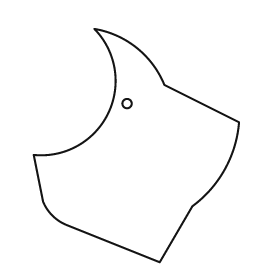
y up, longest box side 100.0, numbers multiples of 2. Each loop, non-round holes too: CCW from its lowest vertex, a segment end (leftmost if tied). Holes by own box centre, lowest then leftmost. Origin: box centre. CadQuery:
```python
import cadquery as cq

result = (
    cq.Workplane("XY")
    .moveTo(10.0, -50.0)
    .lineTo(24.0, -26.0)
    .threePointArc((38.0, -10.0), (44.0, 10.0))
    .lineTo(12.0, 26.0)
    .threePointArc((0.0, 42.0), (-18.0, 50.0))
    .threePointArc((-12.0, 14.0), (-44.0, -4.0))
    .lineTo(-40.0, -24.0)
    .threePointArc((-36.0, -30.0), (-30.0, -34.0))
    .close()
    .moveTo(-4.0, 18.0)
    .circle(2.0)
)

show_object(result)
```